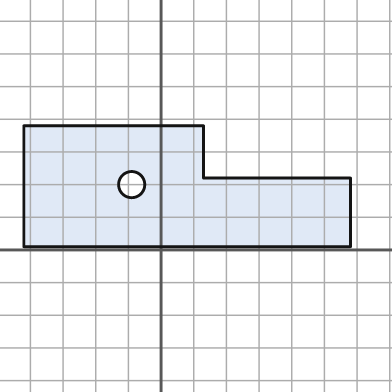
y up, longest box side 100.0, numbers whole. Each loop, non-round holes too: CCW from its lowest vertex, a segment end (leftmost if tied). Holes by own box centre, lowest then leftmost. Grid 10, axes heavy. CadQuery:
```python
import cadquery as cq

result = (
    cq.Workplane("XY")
    .moveTo(-42.0, 1.0)
    .lineTo(58.0, 1.0)
    .lineTo(58.0, 22.0)
    .lineTo(13.0, 22.0)
    .lineTo(13.0, 38.0)
    .lineTo(-42.0, 38.0)
    .close()
    .moveTo(-9.0, 20.0)
    .circle(4.0)
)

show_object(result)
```